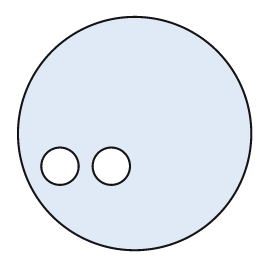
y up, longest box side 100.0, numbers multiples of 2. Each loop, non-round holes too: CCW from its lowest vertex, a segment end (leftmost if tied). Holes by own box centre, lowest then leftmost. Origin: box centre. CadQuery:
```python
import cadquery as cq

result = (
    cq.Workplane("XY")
    .moveTo(0.0, 0.0)
    .circle(50.0)
    .moveTo(-32.0, -14.0)
    .circle(8.0)
    .moveTo(-10.0, -14.0)
    .circle(8.0)
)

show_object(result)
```